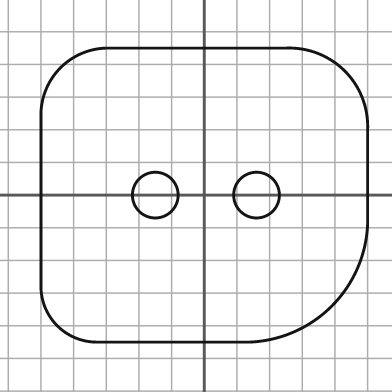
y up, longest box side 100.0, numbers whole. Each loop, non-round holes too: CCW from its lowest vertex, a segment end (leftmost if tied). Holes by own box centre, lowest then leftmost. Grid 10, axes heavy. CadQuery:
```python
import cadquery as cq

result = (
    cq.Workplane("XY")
    .moveTo(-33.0, -45.0)
    .lineTo(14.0, -45.0)
    .threePointArc((39.0, -34.0), (50.0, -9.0))
    .lineTo(50.0, 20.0)
    .threePointArc((43.0, 38.0), (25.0, 45.0))
    .lineTo(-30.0, 45.0)
    .threePointArc((-44.0, 39.0), (-50.0, 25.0))
    .lineTo(-50.0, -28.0)
    .threePointArc((-45.0, -40.0), (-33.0, -45.0))
    .close()
    .moveTo(-15.0, 0.0)
    .circle(7.0)
    .moveTo(16.0, 0.0)
    .circle(7.0)
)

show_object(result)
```